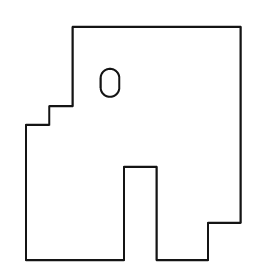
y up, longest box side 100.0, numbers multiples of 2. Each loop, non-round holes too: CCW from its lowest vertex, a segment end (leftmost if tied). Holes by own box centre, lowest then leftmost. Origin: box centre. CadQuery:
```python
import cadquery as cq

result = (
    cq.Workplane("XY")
    .moveTo(-46.0, -50.0)
    .lineTo(-4.0, -50.0)
    .lineTo(-4.0, -10.0)
    .lineTo(10.0, -10.0)
    .lineTo(10.0, -50.0)
    .lineTo(32.0, -50.0)
    .lineTo(32.0, -34.0)
    .lineTo(46.0, -34.0)
    .lineTo(46.0, 50.0)
    .lineTo(-26.0, 50.0)
    .lineTo(-26.0, 16.0)
    .lineTo(-36.0, 16.0)
    .lineTo(-36.0, 8.0)
    .lineTo(-46.0, 8.0)
    .close()
    .moveTo(-14.0, 24.0)
    .threePointArc((-10.0, 20.0), (-6.0, 24.0))
    .lineTo(-6.0, 28.0)
    .threePointArc((-10.0, 32.0), (-14.0, 28.0))
    .close()
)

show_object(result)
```